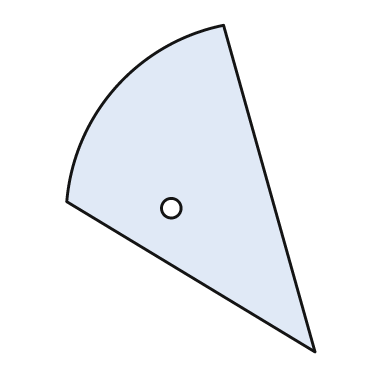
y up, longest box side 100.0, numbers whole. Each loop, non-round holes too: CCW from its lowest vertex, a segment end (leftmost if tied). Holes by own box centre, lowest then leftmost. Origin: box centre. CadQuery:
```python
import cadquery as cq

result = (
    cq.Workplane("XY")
    .moveTo(38.0, -50.0)
    .lineTo(10.0, 50.0)
    .threePointArc((-23.0, 31.0), (-38.0, -4.0))
    .close()
    .moveTo(-6.0, -6.0)
    .circle(3.0)
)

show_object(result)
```